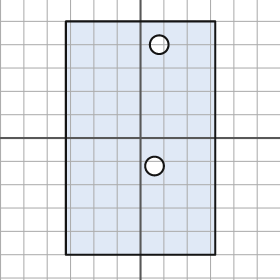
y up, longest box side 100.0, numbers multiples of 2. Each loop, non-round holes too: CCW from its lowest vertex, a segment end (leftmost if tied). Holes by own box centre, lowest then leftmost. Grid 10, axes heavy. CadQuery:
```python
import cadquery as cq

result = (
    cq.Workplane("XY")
    .moveTo(-32.0, -50.0)
    .lineTo(32.0, -50.0)
    .lineTo(32.0, 50.0)
    .lineTo(-32.0, 50.0)
    .close()
    .moveTo(6.0, -12.0)
    .circle(4.0)
    .moveTo(8.0, 40.0)
    .circle(4.0)
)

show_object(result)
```